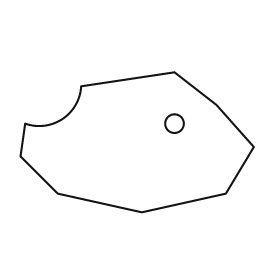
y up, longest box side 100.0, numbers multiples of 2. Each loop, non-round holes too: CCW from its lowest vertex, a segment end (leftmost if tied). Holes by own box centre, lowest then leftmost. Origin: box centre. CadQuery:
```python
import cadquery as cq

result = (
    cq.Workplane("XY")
    .moveTo(2.0, -30.0)
    .lineTo(38.0, -22.0)
    .lineTo(50.0, -2.0)
    .lineTo(34.0, 16.0)
    .lineTo(16.0, 30.0)
    .lineTo(-24.0, 24.0)
    .threePointArc((-32.0, 10.0), (-48.0, 8.0))
    .lineTo(-50.0, -6.0)
    .lineTo(-34.0, -22.0)
    .close()
    .moveTo(16.0, 8.0)
    .circle(4.0)
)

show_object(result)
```